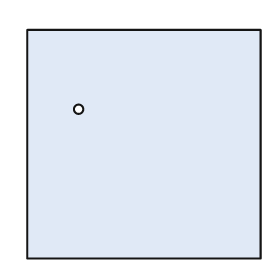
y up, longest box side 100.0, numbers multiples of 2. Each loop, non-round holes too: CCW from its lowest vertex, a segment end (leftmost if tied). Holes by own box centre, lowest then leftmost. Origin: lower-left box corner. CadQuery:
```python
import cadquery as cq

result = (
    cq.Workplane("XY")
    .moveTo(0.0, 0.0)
    .lineTo(100.0, 0.0)
    .lineTo(100.0, 98.0)
    .lineTo(0.0, 98.0)
    .close()
    .moveTo(22.0, 64.0)
    .circle(2.0)
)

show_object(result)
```